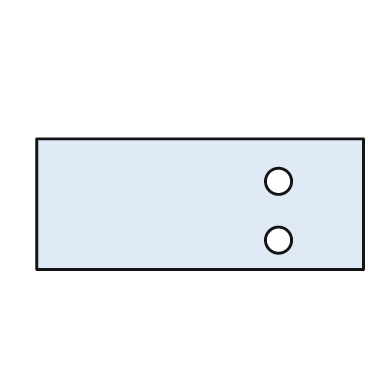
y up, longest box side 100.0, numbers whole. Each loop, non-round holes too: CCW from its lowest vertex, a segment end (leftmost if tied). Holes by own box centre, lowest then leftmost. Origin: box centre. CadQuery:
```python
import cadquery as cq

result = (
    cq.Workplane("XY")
    .moveTo(-50.0, -20.0)
    .lineTo(50.0, -20.0)
    .lineTo(50.0, 20.0)
    .lineTo(-50.0, 20.0)
    .close()
    .moveTo(24.0, -11.0)
    .circle(4.0)
    .moveTo(24.0, 7.0)
    .circle(4.0)
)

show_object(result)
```